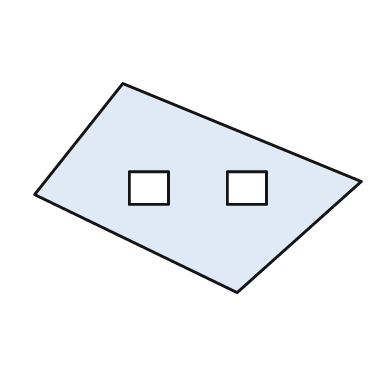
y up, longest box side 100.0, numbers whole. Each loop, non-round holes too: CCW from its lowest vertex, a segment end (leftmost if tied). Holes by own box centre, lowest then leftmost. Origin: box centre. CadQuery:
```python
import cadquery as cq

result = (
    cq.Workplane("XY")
    .moveTo(12.0, -32.0)
    .lineTo(50.0, 2.0)
    .lineTo(-23.0, 32.0)
    .lineTo(-50.0, -2.0)
    .close()
    .moveTo(-21.0, -5.0)
    .lineTo(-9.0, -5.0)
    .lineTo(-9.0, 5.0)
    .lineTo(-21.0, 5.0)
    .close()
    .moveTo(9.0, -5.0)
    .lineTo(21.0, -5.0)
    .lineTo(21.0, 5.0)
    .lineTo(9.0, 5.0)
    .close()
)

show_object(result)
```